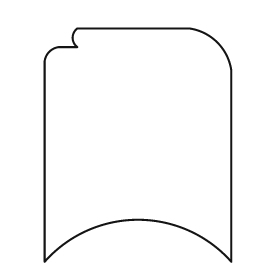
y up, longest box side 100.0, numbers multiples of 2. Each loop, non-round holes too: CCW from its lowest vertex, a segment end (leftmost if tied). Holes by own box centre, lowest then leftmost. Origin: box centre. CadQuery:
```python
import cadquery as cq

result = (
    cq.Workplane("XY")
    .moveTo(-40.0, -50.0)
    .threePointArc((0.0, -32.0), (40.0, -50.0))
    .lineTo(40.0, 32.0)
    .threePointArc((34.0, 44.0), (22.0, 50.0))
    .lineTo(-26.0, 50.0)
    .threePointArc((-28.0, 46.0), (-26.0, 42.0))
    .lineTo(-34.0, 42.0)
    .threePointArc((-38.0, 40.0), (-40.0, 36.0))
    .close()
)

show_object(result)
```